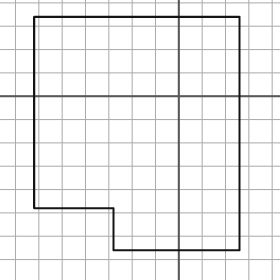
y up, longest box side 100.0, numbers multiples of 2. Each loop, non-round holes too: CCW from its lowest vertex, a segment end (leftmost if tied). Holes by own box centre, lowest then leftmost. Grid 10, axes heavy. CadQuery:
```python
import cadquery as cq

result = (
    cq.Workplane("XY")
    .moveTo(-28.0, -66.0)
    .lineTo(26.0, -66.0)
    .lineTo(26.0, 34.0)
    .lineTo(-62.0, 34.0)
    .lineTo(-62.0, -48.0)
    .lineTo(-28.0, -48.0)
    .close()
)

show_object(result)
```